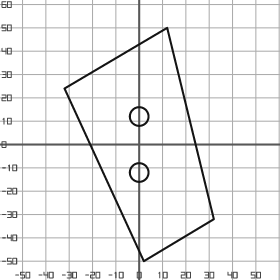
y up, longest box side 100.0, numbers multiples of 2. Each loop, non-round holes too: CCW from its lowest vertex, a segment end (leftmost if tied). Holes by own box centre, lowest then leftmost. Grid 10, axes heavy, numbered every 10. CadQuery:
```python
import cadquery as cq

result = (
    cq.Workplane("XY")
    .moveTo(2.0, -50.0)
    .lineTo(32.0, -32.0)
    .lineTo(12.0, 50.0)
    .lineTo(-32.0, 24.0)
    .close()
    .moveTo(0.0, -12.0)
    .circle(4.0)
    .moveTo(0.0, 12.0)
    .circle(4.0)
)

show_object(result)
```